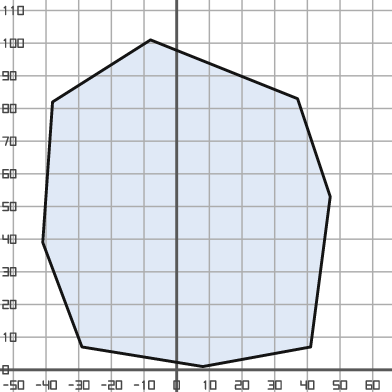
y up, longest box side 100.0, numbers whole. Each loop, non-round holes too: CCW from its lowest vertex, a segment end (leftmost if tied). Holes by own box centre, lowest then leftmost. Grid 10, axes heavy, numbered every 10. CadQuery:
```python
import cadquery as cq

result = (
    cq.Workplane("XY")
    .moveTo(8.0, 1.0)
    .lineTo(41.0, 7.0)
    .lineTo(47.0, 53.0)
    .lineTo(37.0, 83.0)
    .lineTo(-8.0, 101.0)
    .lineTo(-38.0, 82.0)
    .lineTo(-41.0, 39.0)
    .lineTo(-29.0, 7.0)
    .close()
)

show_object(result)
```